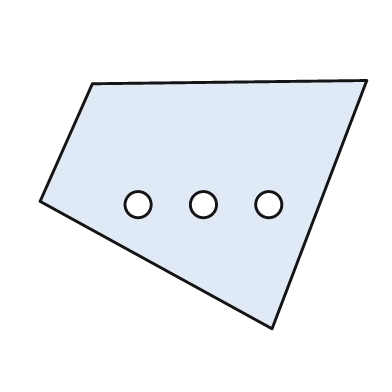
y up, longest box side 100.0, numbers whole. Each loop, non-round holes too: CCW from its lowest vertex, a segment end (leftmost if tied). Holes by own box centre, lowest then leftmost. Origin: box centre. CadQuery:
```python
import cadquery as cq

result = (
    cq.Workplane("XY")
    .moveTo(21.0, -38.0)
    .lineTo(50.0, 38.0)
    .lineTo(-34.0, 37.0)
    .lineTo(-50.0, 1.0)
    .close()
    .moveTo(-20.0, 0.0)
    .circle(4.0)
    .moveTo(0.0, 0.0)
    .circle(4.0)
    .moveTo(20.0, 0.0)
    .circle(4.0)
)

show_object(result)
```